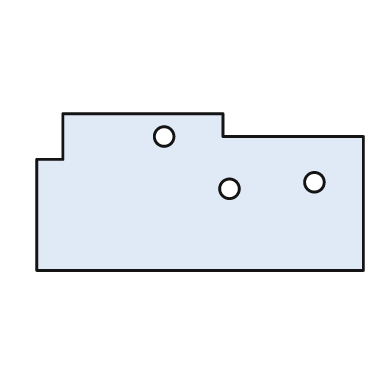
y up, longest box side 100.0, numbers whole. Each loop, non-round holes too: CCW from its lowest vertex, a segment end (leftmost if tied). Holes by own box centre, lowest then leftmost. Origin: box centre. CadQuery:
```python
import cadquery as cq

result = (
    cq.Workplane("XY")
    .moveTo(-50.0, -24.0)
    .lineTo(50.0, -24.0)
    .lineTo(50.0, 17.0)
    .lineTo(7.0, 17.0)
    .lineTo(7.0, 24.0)
    .lineTo(-42.0, 24.0)
    .lineTo(-42.0, 10.0)
    .lineTo(-50.0, 10.0)
    .close()
    .moveTo(9.0, 1.0)
    .circle(3.0)
    .moveTo(35.0, 3.0)
    .circle(3.0)
    .moveTo(-11.0, 17.0)
    .circle(3.0)
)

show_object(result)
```